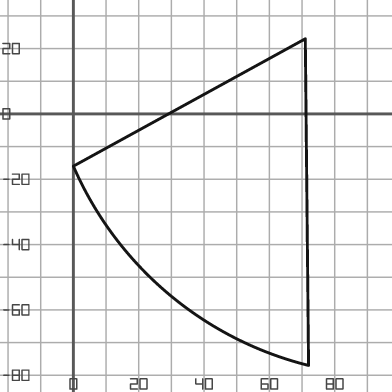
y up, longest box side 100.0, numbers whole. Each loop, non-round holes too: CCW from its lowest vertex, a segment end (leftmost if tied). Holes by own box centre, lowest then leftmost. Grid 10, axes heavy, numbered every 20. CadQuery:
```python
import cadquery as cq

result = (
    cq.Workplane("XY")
    .moveTo(72.0, -77.0)
    .lineTo(71.0, 23.0)
    .lineTo(0.0, -16.0)
    .threePointArc((29.0, -55.0), (72.0, -77.0))
    .close()
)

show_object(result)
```